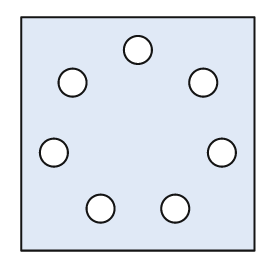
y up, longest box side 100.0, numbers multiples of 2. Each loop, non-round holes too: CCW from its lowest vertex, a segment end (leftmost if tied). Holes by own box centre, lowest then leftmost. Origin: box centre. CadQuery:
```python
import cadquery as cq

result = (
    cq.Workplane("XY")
    .moveTo(-50.0, -50.0)
    .lineTo(50.0, -50.0)
    .lineTo(50.0, 50.0)
    .lineTo(-50.0, 50.0)
    .close()
    .moveTo(-16.0, -32.0)
    .circle(6.0)
    .moveTo(16.0, -32.0)
    .circle(6.0)
    .moveTo(-36.0, -8.0)
    .circle(6.0)
    .moveTo(36.0, -8.0)
    .circle(6.0)
    .moveTo(-28.0, 22.0)
    .circle(6.0)
    .moveTo(28.0, 22.0)
    .circle(6.0)
    .moveTo(0.0, 36.0)
    .circle(6.0)
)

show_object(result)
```